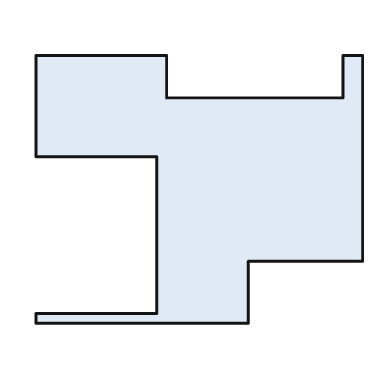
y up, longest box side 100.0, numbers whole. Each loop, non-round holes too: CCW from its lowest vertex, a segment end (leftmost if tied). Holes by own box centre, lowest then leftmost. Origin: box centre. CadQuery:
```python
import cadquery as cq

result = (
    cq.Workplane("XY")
    .moveTo(-50.0, -41.0)
    .lineTo(15.0, -41.0)
    .lineTo(15.0, -22.0)
    .lineTo(50.0, -22.0)
    .lineTo(50.0, 41.0)
    .lineTo(44.0, 41.0)
    .lineTo(44.0, 28.0)
    .lineTo(-10.0, 28.0)
    .lineTo(-10.0, 41.0)
    .lineTo(-50.0, 41.0)
    .lineTo(-50.0, 10.0)
    .lineTo(-13.0, 10.0)
    .lineTo(-13.0, -38.0)
    .lineTo(-50.0, -38.0)
    .close()
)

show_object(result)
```